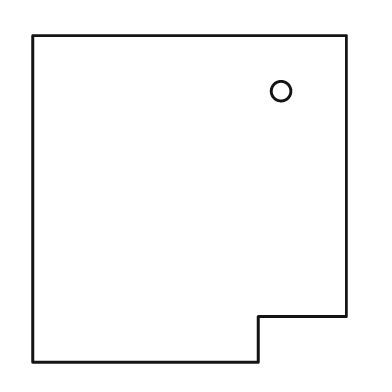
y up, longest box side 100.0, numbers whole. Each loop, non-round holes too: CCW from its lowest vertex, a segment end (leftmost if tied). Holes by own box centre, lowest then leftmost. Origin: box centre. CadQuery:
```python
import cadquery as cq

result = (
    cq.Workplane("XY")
    .moveTo(-48.0, -50.0)
    .lineTo(21.0, -50.0)
    .lineTo(21.0, -36.0)
    .lineTo(48.0, -36.0)
    .lineTo(48.0, 50.0)
    .lineTo(-48.0, 50.0)
    .close()
    .moveTo(28.0, 33.0)
    .circle(3.0)
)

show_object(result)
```